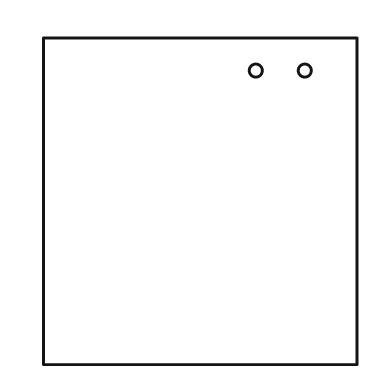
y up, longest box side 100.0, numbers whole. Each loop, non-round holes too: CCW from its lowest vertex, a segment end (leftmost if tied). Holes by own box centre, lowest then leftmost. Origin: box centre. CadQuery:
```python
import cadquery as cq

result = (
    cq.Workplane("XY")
    .moveTo(-48.0, -50.0)
    .lineTo(48.0, -50.0)
    .lineTo(48.0, 50.0)
    .lineTo(-48.0, 50.0)
    .close()
    .moveTo(17.0, 40.0)
    .circle(2.0)
    .moveTo(32.0, 40.0)
    .circle(2.0)
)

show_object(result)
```